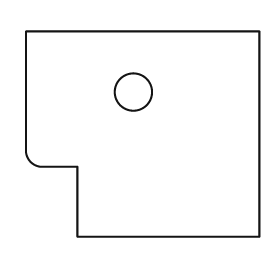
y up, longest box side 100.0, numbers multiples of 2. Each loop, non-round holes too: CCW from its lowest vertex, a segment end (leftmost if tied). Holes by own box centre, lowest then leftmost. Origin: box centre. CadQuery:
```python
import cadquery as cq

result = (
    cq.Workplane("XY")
    .moveTo(-28.0, -44.0)
    .lineTo(50.0, -44.0)
    .lineTo(50.0, 44.0)
    .lineTo(-50.0, 44.0)
    .lineTo(-50.0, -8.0)
    .threePointArc((-48.0, -12.0), (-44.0, -14.0))
    .lineTo(-28.0, -14.0)
    .close()
    .moveTo(-4.0, 18.0)
    .circle(8.0)
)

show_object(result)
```